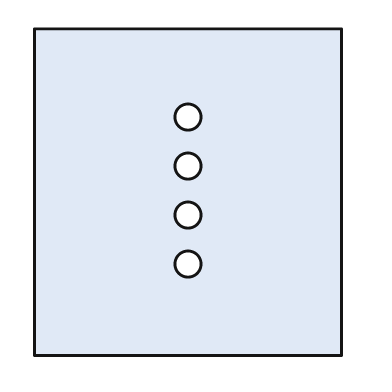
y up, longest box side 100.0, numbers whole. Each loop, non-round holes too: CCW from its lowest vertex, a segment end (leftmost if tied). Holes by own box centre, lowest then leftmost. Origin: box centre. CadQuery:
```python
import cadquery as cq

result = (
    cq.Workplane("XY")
    .moveTo(-47.0, -50.0)
    .lineTo(47.0, -50.0)
    .lineTo(47.0, 50.0)
    .lineTo(-47.0, 50.0)
    .close()
    .moveTo(0.0, -22.0)
    .circle(4.0)
    .moveTo(0.0, -7.0)
    .circle(4.0)
    .moveTo(0.0, 8.0)
    .circle(4.0)
    .moveTo(0.0, 23.0)
    .circle(4.0)
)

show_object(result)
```